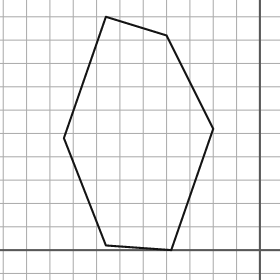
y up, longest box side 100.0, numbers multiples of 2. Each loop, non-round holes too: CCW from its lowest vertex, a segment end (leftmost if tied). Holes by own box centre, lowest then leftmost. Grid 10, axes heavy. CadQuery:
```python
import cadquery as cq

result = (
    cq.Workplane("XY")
    .moveTo(-38.0, 0.0)
    .lineTo(-20.0, 52.0)
    .lineTo(-40.0, 92.0)
    .lineTo(-66.0, 100.0)
    .lineTo(-84.0, 48.0)
    .lineTo(-66.0, 2.0)
    .close()
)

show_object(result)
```